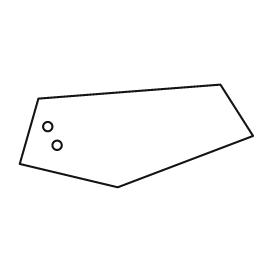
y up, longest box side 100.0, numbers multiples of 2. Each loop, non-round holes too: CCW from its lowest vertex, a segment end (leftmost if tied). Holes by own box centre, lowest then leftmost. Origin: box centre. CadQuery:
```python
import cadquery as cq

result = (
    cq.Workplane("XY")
    .moveTo(-8.0, -22.0)
    .lineTo(50.0, 0.0)
    .lineTo(36.0, 22.0)
    .lineTo(-42.0, 16.0)
    .lineTo(-50.0, -12.0)
    .close()
    .moveTo(-34.0, -4.0)
    .circle(2.0)
    .moveTo(-38.0, 4.0)
    .circle(2.0)
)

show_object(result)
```